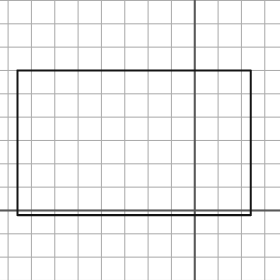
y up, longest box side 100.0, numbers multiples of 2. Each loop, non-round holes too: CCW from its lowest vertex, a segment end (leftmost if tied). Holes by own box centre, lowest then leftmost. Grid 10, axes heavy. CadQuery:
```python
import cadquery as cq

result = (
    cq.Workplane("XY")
    .moveTo(-76.0, -2.0)
    .lineTo(24.0, -2.0)
    .lineTo(24.0, 60.0)
    .lineTo(-76.0, 60.0)
    .close()
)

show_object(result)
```